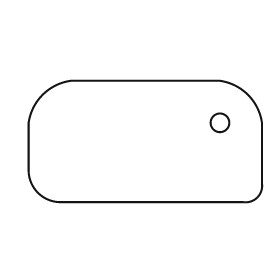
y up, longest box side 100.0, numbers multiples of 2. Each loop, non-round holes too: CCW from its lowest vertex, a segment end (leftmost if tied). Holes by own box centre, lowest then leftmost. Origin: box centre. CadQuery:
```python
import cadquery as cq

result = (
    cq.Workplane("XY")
    .moveTo(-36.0, -26.0)
    .lineTo(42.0, -26.0)
    .threePointArc((48.0, -24.0), (50.0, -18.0))
    .lineTo(50.0, 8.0)
    .threePointArc((44.0, 20.0), (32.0, 26.0))
    .lineTo(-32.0, 26.0)
    .threePointArc((-44.0, 20.0), (-50.0, 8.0))
    .lineTo(-50.0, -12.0)
    .threePointArc((-46.0, -22.0), (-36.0, -26.0))
    .close()
    .moveTo(32.0, 8.0)
    .circle(4.0)
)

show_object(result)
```